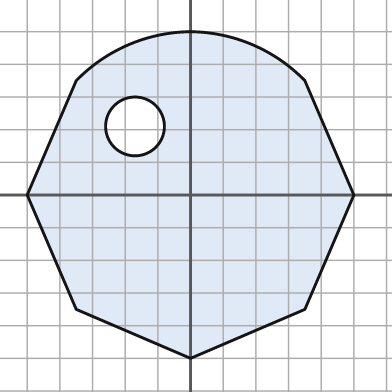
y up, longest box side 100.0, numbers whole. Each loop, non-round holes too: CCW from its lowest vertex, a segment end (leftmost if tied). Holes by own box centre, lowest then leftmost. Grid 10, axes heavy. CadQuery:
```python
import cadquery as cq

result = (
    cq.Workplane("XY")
    .moveTo(0.0, -50.0)
    .lineTo(35.0, -35.0)
    .lineTo(50.0, 0.0)
    .lineTo(35.0, 35.0)
    .threePointArc((19.0, 46.0), (0.0, 50.0))
    .threePointArc((-19.0, 46.0), (-35.0, 35.0))
    .lineTo(-50.0, 0.0)
    .lineTo(-35.0, -35.0)
    .close()
    .moveTo(-17.0, 21.0)
    .circle(9.0)
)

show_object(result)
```